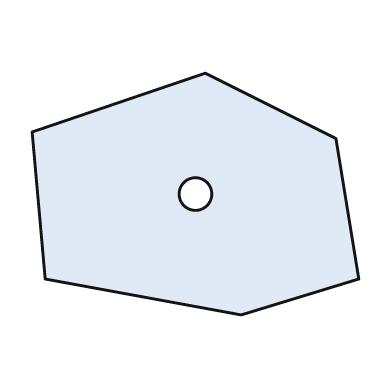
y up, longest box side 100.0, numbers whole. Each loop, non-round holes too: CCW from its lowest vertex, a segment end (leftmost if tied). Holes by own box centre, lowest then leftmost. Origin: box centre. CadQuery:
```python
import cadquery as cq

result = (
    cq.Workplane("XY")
    .moveTo(14.0, -37.0)
    .lineTo(50.0, -26.0)
    .lineTo(43.0, 17.0)
    .lineTo(3.0, 37.0)
    .lineTo(-50.0, 19.0)
    .lineTo(-46.0, -26.0)
    .close()
    .moveTo(0.0, 0.0)
    .circle(5.0)
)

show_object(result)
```